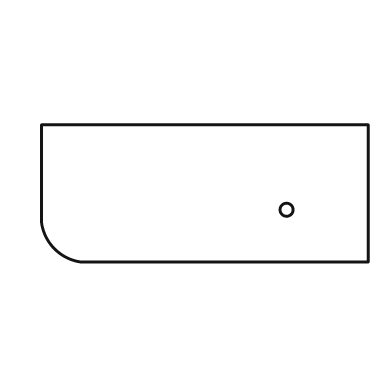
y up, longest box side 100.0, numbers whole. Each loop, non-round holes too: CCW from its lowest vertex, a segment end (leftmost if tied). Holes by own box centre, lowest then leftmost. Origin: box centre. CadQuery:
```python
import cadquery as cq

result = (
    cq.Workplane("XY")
    .moveTo(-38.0, -21.0)
    .lineTo(50.0, -21.0)
    .lineTo(50.0, 21.0)
    .lineTo(-50.0, 21.0)
    .lineTo(-50.0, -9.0)
    .threePointArc((-46.0, -17.0), (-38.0, -21.0))
    .close()
    .moveTo(25.0, -5.0)
    .circle(2.0)
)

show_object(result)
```